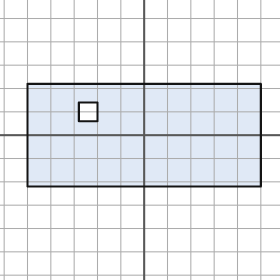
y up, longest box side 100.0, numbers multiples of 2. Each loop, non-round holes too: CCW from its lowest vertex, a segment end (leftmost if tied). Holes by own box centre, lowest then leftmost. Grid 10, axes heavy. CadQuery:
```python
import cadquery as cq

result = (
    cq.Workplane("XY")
    .moveTo(-50.0, -22.0)
    .lineTo(50.0, -22.0)
    .lineTo(50.0, 22.0)
    .lineTo(-50.0, 22.0)
    .close()
    .moveTo(-28.0, 6.0)
    .lineTo(-20.0, 6.0)
    .lineTo(-20.0, 14.0)
    .lineTo(-28.0, 14.0)
    .close()
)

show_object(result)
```